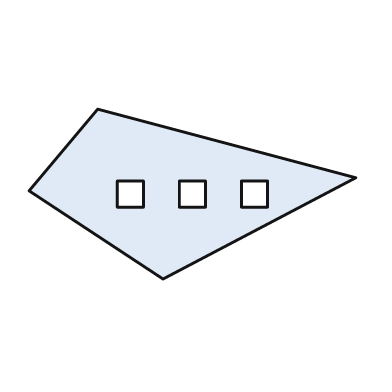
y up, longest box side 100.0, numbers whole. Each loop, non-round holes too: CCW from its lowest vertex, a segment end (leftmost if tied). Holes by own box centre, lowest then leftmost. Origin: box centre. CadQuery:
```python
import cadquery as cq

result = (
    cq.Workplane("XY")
    .moveTo(-9.0, -26.0)
    .lineTo(50.0, 5.0)
    .lineTo(-29.0, 26.0)
    .lineTo(-50.0, 1.0)
    .close()
    .moveTo(-23.0, -4.0)
    .lineTo(-15.0, -4.0)
    .lineTo(-15.0, 4.0)
    .lineTo(-23.0, 4.0)
    .close()
    .moveTo(-4.0, -4.0)
    .lineTo(4.0, -4.0)
    .lineTo(4.0, 4.0)
    .lineTo(-4.0, 4.0)
    .close()
    .moveTo(15.0, -4.0)
    .lineTo(23.0, -4.0)
    .lineTo(23.0, 4.0)
    .lineTo(15.0, 4.0)
    .close()
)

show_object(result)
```